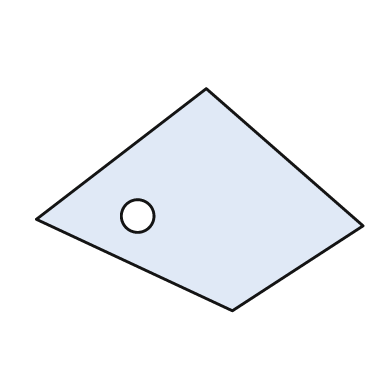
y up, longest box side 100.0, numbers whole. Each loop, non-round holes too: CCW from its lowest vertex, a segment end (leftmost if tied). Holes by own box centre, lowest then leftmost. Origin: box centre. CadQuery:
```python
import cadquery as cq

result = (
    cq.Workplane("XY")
    .moveTo(10.0, -34.0)
    .lineTo(50.0, -8.0)
    .lineTo(2.0, 34.0)
    .lineTo(-50.0, -6.0)
    .close()
    .moveTo(-19.0, -5.0)
    .circle(5.0)
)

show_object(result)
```